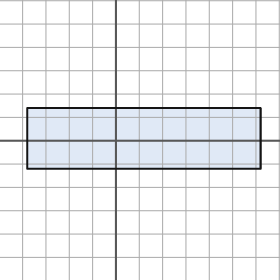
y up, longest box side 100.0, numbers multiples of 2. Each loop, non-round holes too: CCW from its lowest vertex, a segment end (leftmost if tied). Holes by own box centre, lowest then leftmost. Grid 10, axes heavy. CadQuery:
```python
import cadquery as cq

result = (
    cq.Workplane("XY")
    .moveTo(-38.0, -12.0)
    .lineTo(62.0, -12.0)
    .lineTo(62.0, 14.0)
    .lineTo(-38.0, 14.0)
    .close()
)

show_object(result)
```